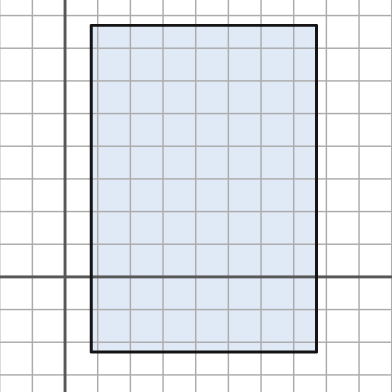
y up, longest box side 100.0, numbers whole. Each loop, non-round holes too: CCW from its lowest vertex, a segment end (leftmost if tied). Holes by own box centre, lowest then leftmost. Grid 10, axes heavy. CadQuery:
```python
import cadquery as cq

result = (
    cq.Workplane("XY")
    .moveTo(8.0, -23.0)
    .lineTo(77.0, -23.0)
    .lineTo(77.0, 77.0)
    .lineTo(8.0, 77.0)
    .close()
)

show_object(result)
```